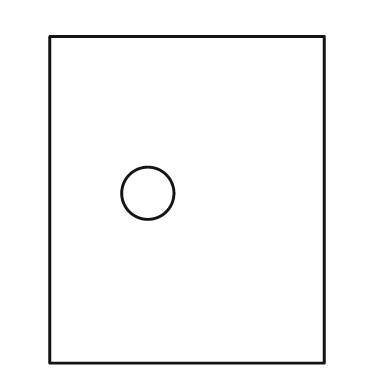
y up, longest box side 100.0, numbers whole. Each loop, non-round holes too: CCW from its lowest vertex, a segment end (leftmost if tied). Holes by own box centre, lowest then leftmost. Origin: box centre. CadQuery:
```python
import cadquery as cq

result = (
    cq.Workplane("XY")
    .moveTo(-42.0, -50.0)
    .lineTo(42.0, -50.0)
    .lineTo(42.0, 50.0)
    .lineTo(-42.0, 50.0)
    .close()
    .moveTo(-12.0, 2.0)
    .circle(8.0)
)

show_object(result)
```